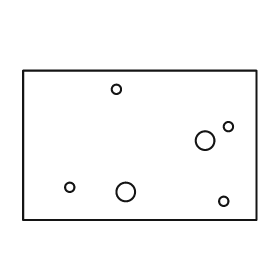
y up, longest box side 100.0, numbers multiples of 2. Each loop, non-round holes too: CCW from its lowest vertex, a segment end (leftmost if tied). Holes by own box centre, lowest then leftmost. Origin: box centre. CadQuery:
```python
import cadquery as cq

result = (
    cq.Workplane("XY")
    .moveTo(-50.0, -32.0)
    .lineTo(50.0, -32.0)
    .lineTo(50.0, 32.0)
    .lineTo(-50.0, 32.0)
    .close()
    .moveTo(36.0, -24.0)
    .circle(2.0)
    .moveTo(-6.0, -20.0)
    .circle(4.0)
    .moveTo(-30.0, -18.0)
    .circle(2.0)
    .moveTo(28.0, 2.0)
    .circle(4.0)
    .moveTo(38.0, 8.0)
    .circle(2.0)
    .moveTo(-10.0, 24.0)
    .circle(2.0)
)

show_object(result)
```